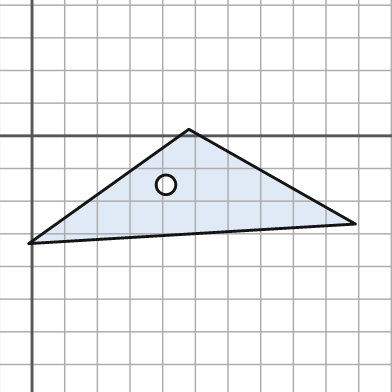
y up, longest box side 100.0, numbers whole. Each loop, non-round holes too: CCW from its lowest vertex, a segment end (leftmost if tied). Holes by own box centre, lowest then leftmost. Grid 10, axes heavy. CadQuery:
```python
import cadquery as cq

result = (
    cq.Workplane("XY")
    .moveTo(-1.0, -33.0)
    .lineTo(99.0, -27.0)
    .lineTo(48.0, 2.0)
    .close()
    .moveTo(41.0, -15.0)
    .circle(3.0)
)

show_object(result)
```